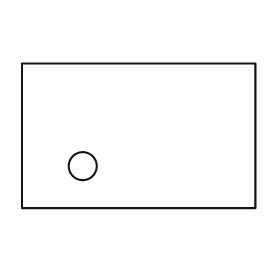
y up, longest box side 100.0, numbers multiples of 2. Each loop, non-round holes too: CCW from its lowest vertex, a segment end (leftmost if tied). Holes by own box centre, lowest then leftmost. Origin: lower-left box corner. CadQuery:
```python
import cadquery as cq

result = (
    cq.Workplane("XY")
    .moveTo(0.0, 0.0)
    .lineTo(100.0, 0.0)
    .lineTo(100.0, 62.0)
    .lineTo(0.0, 62.0)
    .close()
    .moveTo(26.0, 18.0)
    .circle(6.0)
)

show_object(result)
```